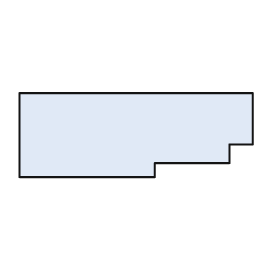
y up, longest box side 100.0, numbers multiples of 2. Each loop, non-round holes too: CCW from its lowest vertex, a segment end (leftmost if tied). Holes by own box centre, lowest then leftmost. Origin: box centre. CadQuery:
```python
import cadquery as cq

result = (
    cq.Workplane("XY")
    .moveTo(-50.0, -18.0)
    .lineTo(8.0, -18.0)
    .lineTo(8.0, -12.0)
    .lineTo(40.0, -12.0)
    .lineTo(40.0, -4.0)
    .lineTo(50.0, -4.0)
    .lineTo(50.0, 18.0)
    .lineTo(-50.0, 18.0)
    .close()
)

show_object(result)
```